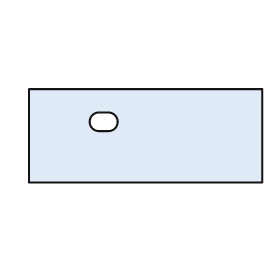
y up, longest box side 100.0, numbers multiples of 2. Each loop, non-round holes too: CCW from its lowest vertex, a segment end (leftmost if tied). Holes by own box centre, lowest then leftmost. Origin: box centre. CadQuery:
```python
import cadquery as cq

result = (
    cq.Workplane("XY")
    .moveTo(-50.0, -20.0)
    .lineTo(50.0, -20.0)
    .lineTo(50.0, 20.0)
    .lineTo(-50.0, 20.0)
    .close()
    .moveTo(-20.0, 2.0)
    .lineTo(-16.0, 2.0)
    .threePointArc((-12.0, 6.0), (-16.0, 10.0))
    .lineTo(-20.0, 10.0)
    .threePointArc((-24.0, 6.0), (-20.0, 2.0))
    .close()
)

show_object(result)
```